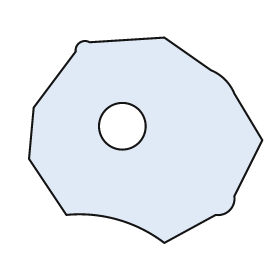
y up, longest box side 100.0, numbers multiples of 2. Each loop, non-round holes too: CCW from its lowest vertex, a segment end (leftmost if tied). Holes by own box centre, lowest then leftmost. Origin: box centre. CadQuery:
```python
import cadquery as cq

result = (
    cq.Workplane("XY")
    .moveTo(8.0, -44.0)
    .lineTo(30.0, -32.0)
    .threePointArc((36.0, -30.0), (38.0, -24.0))
    .lineTo(50.0, 0.0)
    .lineTo(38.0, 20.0)
    .threePointArc((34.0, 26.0), (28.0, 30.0))
    .lineTo(8.0, 44.0)
    .lineTo(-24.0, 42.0)
    .threePointArc((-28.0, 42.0), (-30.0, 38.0))
    .lineTo(-48.0, 14.0)
    .lineTo(-50.0, -8.0)
    .lineTo(-34.0, -32.0)
    .threePointArc((-12.0, -34.0), (8.0, -44.0))
    .close()
    .moveTo(-10.0, 6.0)
    .circle(10.0)
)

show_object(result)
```